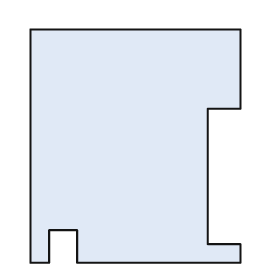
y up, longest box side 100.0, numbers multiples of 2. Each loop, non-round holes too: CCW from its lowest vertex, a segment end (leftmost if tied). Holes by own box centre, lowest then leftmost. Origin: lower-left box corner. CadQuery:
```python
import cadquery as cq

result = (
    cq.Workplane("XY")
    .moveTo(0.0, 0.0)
    .lineTo(8.0, 0.0)
    .lineTo(8.0, 14.0)
    .lineTo(20.0, 14.0)
    .lineTo(20.0, 0.0)
    .lineTo(90.0, 0.0)
    .lineTo(90.0, 8.0)
    .lineTo(76.0, 8.0)
    .lineTo(76.0, 66.0)
    .lineTo(90.0, 66.0)
    .lineTo(90.0, 100.0)
    .lineTo(0.0, 100.0)
    .close()
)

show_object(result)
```